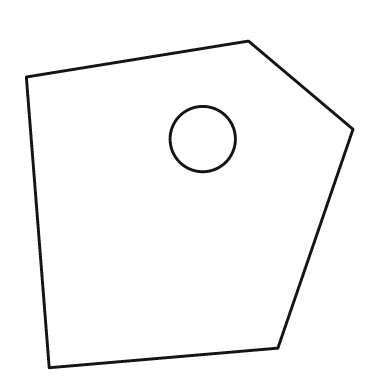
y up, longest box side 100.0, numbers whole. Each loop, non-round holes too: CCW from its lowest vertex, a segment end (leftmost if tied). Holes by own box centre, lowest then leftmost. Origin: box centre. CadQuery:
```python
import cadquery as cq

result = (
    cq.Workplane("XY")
    .moveTo(-43.0, -50.0)
    .lineTo(27.0, -44.0)
    .lineTo(50.0, 23.0)
    .lineTo(18.0, 50.0)
    .lineTo(-50.0, 39.0)
    .close()
    .moveTo(4.0, 20.0)
    .circle(10.0)
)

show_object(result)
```